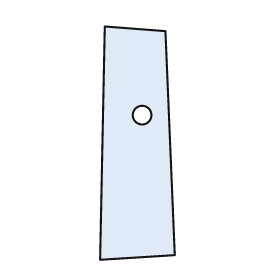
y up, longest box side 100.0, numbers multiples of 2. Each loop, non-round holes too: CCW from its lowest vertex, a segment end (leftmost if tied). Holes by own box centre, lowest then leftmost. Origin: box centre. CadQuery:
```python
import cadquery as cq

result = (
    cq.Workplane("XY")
    .moveTo(-16.0, -50.0)
    .lineTo(16.0, -48.0)
    .lineTo(12.0, 48.0)
    .lineTo(-14.0, 50.0)
    .close()
    .moveTo(2.0, 12.0)
    .circle(4.0)
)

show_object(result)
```